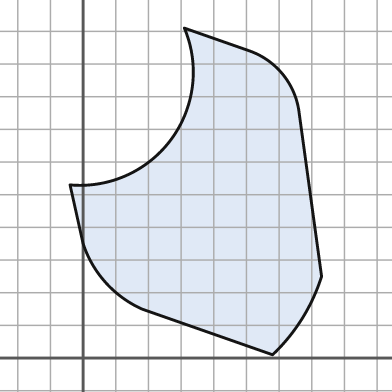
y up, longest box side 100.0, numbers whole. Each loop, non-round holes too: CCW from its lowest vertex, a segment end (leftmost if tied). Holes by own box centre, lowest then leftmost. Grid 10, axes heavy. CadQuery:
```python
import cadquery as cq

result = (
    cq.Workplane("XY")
    .moveTo(58.0, 1.0)
    .threePointArc((67.0, 12.0), (73.0, 25.0))
    .lineTo(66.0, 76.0)
    .threePointArc((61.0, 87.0), (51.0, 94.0))
    .lineTo(31.0, 101.0)
    .threePointArc((27.0, 67.0), (-4.0, 53.0))
    .lineTo(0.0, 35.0)
    .threePointArc((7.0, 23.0), (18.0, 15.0))
    .close()
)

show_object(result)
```